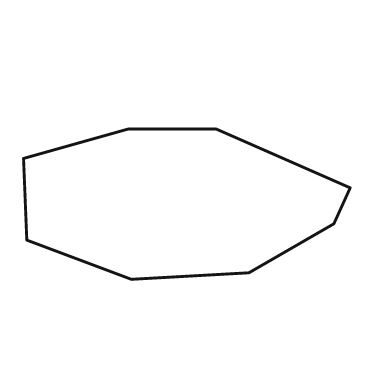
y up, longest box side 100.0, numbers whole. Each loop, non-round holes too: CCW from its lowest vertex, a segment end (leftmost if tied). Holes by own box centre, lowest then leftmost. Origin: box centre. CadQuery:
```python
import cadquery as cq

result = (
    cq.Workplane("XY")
    .moveTo(-17.0, -23.0)
    .lineTo(19.0, -21.0)
    .lineTo(45.0, -6.0)
    .lineTo(50.0, 5.0)
    .lineTo(9.0, 23.0)
    .lineTo(-18.0, 23.0)
    .lineTo(-50.0, 14.0)
    .lineTo(-49.0, -11.0)
    .close()
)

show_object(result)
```